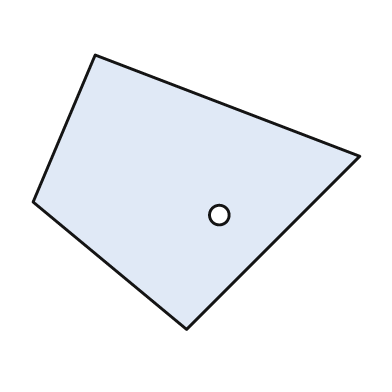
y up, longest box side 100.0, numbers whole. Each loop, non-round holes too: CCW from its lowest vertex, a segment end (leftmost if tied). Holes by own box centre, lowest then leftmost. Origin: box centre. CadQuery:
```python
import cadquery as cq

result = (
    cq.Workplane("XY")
    .moveTo(-3.0, -42.0)
    .lineTo(50.0, 11.0)
    .lineTo(-31.0, 42.0)
    .lineTo(-50.0, -3.0)
    .close()
    .moveTo(7.0, -7.0)
    .circle(3.0)
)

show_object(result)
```